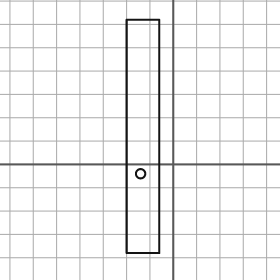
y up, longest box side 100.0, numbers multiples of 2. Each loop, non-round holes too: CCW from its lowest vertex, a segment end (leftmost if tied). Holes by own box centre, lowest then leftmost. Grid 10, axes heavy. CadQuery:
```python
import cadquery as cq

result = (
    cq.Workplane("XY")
    .moveTo(-20.0, -38.0)
    .lineTo(-6.0, -38.0)
    .lineTo(-6.0, 62.0)
    .lineTo(-20.0, 62.0)
    .close()
    .moveTo(-14.0, -4.0)
    .circle(2.0)
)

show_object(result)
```